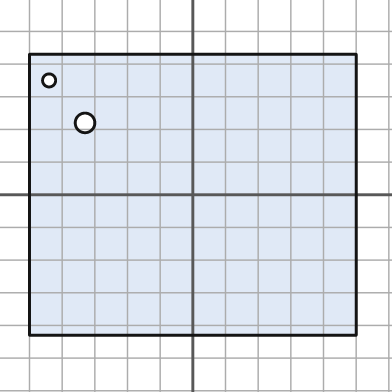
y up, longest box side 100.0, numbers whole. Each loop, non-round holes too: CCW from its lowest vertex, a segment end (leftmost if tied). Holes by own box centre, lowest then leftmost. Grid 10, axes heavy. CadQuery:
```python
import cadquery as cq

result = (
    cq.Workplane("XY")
    .moveTo(-50.0, -43.0)
    .lineTo(50.0, -43.0)
    .lineTo(50.0, 43.0)
    .lineTo(-50.0, 43.0)
    .close()
    .moveTo(-33.0, 22.0)
    .circle(3.0)
    .moveTo(-44.0, 35.0)
    .circle(2.0)
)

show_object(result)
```